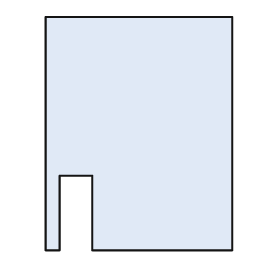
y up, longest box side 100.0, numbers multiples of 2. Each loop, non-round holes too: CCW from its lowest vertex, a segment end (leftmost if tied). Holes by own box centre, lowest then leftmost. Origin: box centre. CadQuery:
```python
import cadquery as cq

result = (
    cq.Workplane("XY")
    .moveTo(-40.0, -50.0)
    .lineTo(-34.0, -50.0)
    .lineTo(-34.0, -18.0)
    .lineTo(-20.0, -18.0)
    .lineTo(-20.0, -50.0)
    .lineTo(40.0, -50.0)
    .lineTo(40.0, 50.0)
    .lineTo(-40.0, 50.0)
    .close()
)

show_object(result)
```